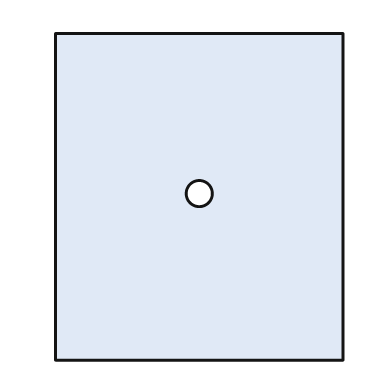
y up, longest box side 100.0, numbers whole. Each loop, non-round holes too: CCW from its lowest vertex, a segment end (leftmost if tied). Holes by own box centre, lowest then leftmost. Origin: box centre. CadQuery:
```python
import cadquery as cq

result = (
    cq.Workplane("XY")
    .moveTo(-44.0, -50.0)
    .lineTo(44.0, -50.0)
    .lineTo(44.0, 50.0)
    .lineTo(-44.0, 50.0)
    .close()
    .moveTo(0.0, 1.0)
    .circle(4.0)
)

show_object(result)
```